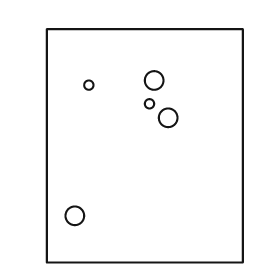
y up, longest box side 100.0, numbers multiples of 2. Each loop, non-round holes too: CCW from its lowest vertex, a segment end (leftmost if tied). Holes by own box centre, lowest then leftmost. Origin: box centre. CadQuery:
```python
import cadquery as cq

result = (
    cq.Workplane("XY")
    .moveTo(-42.0, -50.0)
    .lineTo(42.0, -50.0)
    .lineTo(42.0, 50.0)
    .lineTo(-42.0, 50.0)
    .close()
    .moveTo(-30.0, -30.0)
    .circle(4.0)
    .moveTo(10.0, 12.0)
    .circle(4.0)
    .moveTo(2.0, 18.0)
    .circle(2.0)
    .moveTo(-24.0, 26.0)
    .circle(2.0)
    .moveTo(4.0, 28.0)
    .circle(4.0)
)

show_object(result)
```